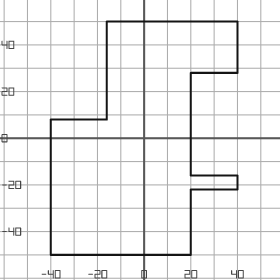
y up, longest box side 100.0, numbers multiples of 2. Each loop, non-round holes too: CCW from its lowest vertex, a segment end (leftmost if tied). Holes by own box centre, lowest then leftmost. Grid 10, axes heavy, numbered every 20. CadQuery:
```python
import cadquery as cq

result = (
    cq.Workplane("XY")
    .moveTo(-40.0, -50.0)
    .lineTo(20.0, -50.0)
    .lineTo(20.0, -22.0)
    .lineTo(40.0, -22.0)
    .lineTo(40.0, -16.0)
    .lineTo(20.0, -16.0)
    .lineTo(20.0, 28.0)
    .lineTo(40.0, 28.0)
    .lineTo(40.0, 50.0)
    .lineTo(-16.0, 50.0)
    .lineTo(-16.0, 8.0)
    .lineTo(-40.0, 8.0)
    .close()
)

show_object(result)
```